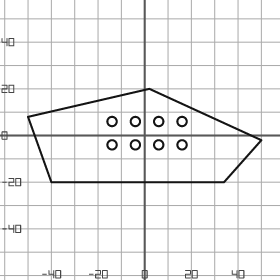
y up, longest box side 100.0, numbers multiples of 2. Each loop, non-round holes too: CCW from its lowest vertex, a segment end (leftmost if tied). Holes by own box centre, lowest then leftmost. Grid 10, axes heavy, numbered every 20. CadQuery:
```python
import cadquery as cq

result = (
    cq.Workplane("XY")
    .moveTo(-40.0, -20.0)
    .lineTo(34.0, -20.0)
    .lineTo(50.0, -2.0)
    .lineTo(2.0, 20.0)
    .lineTo(-50.0, 8.0)
    .close()
    .moveTo(-14.0, -4.0)
    .circle(2.0)
    .moveTo(-4.0, -4.0)
    .circle(2.0)
    .moveTo(6.0, -4.0)
    .circle(2.0)
    .moveTo(16.0, -4.0)
    .circle(2.0)
    .moveTo(-14.0, 6.0)
    .circle(2.0)
    .moveTo(-4.0, 6.0)
    .circle(2.0)
    .moveTo(6.0, 6.0)
    .circle(2.0)
    .moveTo(16.0, 6.0)
    .circle(2.0)
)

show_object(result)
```